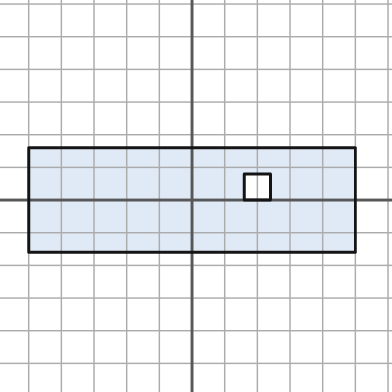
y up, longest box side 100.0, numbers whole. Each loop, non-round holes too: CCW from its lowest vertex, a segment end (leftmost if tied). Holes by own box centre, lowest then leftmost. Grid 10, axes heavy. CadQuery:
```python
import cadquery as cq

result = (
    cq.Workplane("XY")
    .moveTo(-50.0, -16.0)
    .lineTo(50.0, -16.0)
    .lineTo(50.0, 16.0)
    .lineTo(-50.0, 16.0)
    .close()
    .moveTo(16.0, 0.0)
    .lineTo(24.0, 0.0)
    .lineTo(24.0, 8.0)
    .lineTo(16.0, 8.0)
    .close()
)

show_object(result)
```